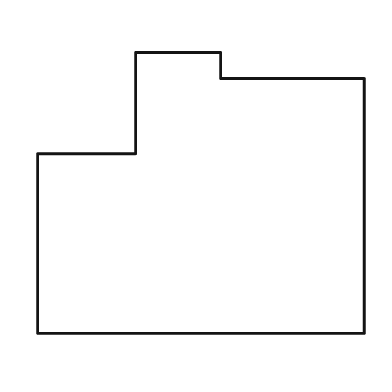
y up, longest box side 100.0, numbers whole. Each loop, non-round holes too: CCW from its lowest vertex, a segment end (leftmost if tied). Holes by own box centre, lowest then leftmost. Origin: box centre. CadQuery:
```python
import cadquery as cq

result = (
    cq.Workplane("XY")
    .moveTo(-50.0, -43.0)
    .lineTo(50.0, -43.0)
    .lineTo(50.0, 35.0)
    .lineTo(6.0, 35.0)
    .lineTo(6.0, 43.0)
    .lineTo(-20.0, 43.0)
    .lineTo(-20.0, 12.0)
    .lineTo(-50.0, 12.0)
    .close()
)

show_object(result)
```